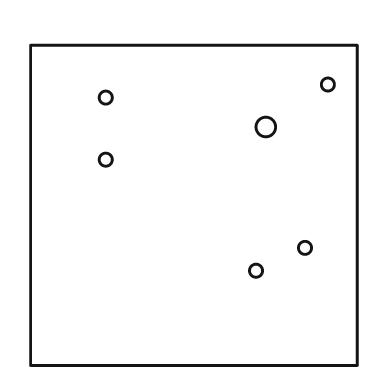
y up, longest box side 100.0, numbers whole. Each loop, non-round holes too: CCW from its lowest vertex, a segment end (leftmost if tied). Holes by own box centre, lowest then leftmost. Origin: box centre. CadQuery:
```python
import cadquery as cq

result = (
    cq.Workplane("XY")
    .moveTo(-50.0, -49.0)
    .lineTo(50.0, -49.0)
    .lineTo(50.0, 49.0)
    .lineTo(-50.0, 49.0)
    .close()
    .moveTo(19.0, -20.0)
    .circle(2.0)
    .moveTo(34.0, -13.0)
    .circle(2.0)
    .moveTo(-27.0, 14.0)
    .circle(2.0)
    .moveTo(22.0, 24.0)
    .circle(3.0)
    .moveTo(-27.0, 33.0)
    .circle(2.0)
    .moveTo(41.0, 37.0)
    .circle(2.0)
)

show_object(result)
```